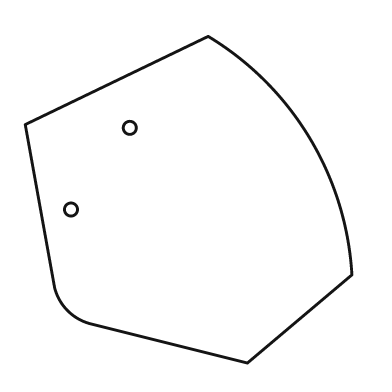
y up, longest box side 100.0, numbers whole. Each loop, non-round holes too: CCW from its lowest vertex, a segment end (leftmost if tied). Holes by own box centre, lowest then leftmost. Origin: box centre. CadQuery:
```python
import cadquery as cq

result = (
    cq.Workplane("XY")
    .moveTo(18.0, -50.0)
    .lineTo(50.0, -23.0)
    .threePointArc((37.0, 19.0), (6.0, 50.0))
    .lineTo(-50.0, 23.0)
    .lineTo(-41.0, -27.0)
    .threePointArc((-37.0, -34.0), (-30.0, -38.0))
    .close()
    .moveTo(-36.0, -3.0)
    .circle(2.0)
    .moveTo(-18.0, 22.0)
    .circle(2.0)
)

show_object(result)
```